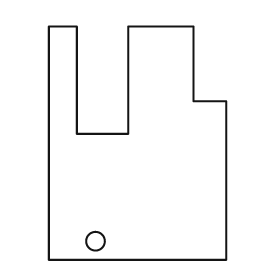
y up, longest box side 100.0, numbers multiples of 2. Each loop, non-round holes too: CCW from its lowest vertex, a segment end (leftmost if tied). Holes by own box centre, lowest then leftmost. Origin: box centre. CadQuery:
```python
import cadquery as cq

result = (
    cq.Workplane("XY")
    .moveTo(-38.0, -50.0)
    .lineTo(38.0, -50.0)
    .lineTo(38.0, 18.0)
    .lineTo(24.0, 18.0)
    .lineTo(24.0, 50.0)
    .lineTo(-4.0, 50.0)
    .lineTo(-4.0, 4.0)
    .lineTo(-26.0, 4.0)
    .lineTo(-26.0, 50.0)
    .lineTo(-38.0, 50.0)
    .close()
    .moveTo(-18.0, -42.0)
    .circle(4.0)
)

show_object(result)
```